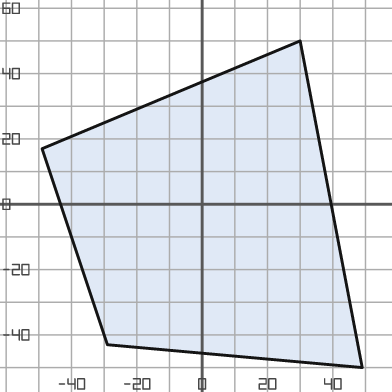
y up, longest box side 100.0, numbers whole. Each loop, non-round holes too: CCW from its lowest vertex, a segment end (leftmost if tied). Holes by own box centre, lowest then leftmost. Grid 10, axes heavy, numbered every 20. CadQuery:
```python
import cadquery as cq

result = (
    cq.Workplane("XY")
    .moveTo(49.0, -50.0)
    .lineTo(30.0, 50.0)
    .lineTo(-49.0, 17.0)
    .lineTo(-29.0, -43.0)
    .close()
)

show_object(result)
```